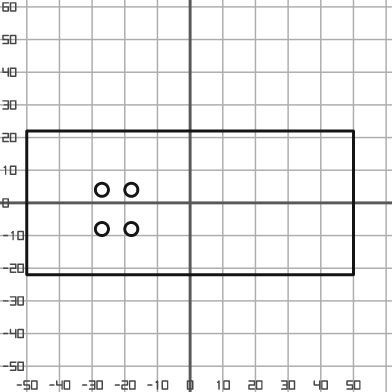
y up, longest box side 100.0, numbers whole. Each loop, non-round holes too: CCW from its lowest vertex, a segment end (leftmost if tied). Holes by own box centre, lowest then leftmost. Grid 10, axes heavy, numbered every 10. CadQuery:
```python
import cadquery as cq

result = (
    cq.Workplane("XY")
    .moveTo(-50.0, -22.0)
    .lineTo(50.0, -22.0)
    .lineTo(50.0, 22.0)
    .lineTo(-50.0, 22.0)
    .close()
    .moveTo(-27.0, -8.0)
    .circle(2.0)
    .moveTo(-18.0, -8.0)
    .circle(2.0)
    .moveTo(-27.0, 4.0)
    .circle(2.0)
    .moveTo(-18.0, 4.0)
    .circle(2.0)
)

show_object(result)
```